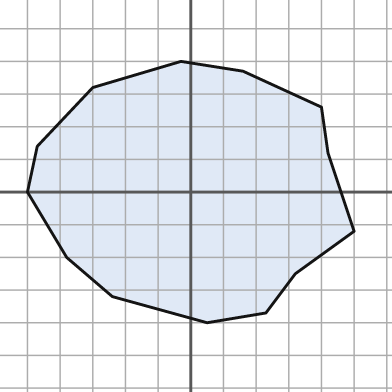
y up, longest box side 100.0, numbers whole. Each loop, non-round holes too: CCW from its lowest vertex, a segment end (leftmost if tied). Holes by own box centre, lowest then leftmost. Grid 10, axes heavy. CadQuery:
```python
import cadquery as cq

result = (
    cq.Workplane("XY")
    .moveTo(5.0, -40.0)
    .lineTo(23.0, -37.0)
    .lineTo(32.0, -25.0)
    .lineTo(50.0, -12.0)
    .lineTo(42.0, 12.0)
    .lineTo(40.0, 26.0)
    .lineTo(16.0, 37.0)
    .lineTo(-3.0, 40.0)
    .lineTo(-30.0, 32.0)
    .lineTo(-47.0, 14.0)
    .lineTo(-50.0, 0.0)
    .lineTo(-38.0, -20.0)
    .lineTo(-24.0, -32.0)
    .close()
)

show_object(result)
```